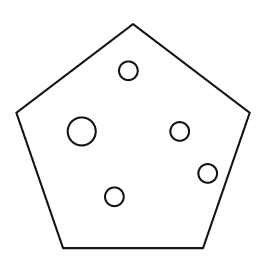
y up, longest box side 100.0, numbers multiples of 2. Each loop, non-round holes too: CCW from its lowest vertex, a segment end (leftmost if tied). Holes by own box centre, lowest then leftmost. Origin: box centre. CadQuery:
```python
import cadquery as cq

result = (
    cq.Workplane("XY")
    .moveTo(-30.0, -48.0)
    .lineTo(30.0, -48.0)
    .lineTo(50.0, 10.0)
    .lineTo(0.0, 48.0)
    .lineTo(-50.0, 10.0)
    .close()
    .moveTo(-8.0, -26.0)
    .circle(4.0)
    .moveTo(32.0, -16.0)
    .circle(4.0)
    .moveTo(-22.0, 2.0)
    .circle(6.0)
    .moveTo(20.0, 2.0)
    .circle(4.0)
    .moveTo(-2.0, 28.0)
    .circle(4.0)
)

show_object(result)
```